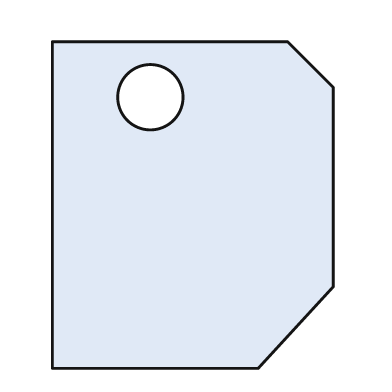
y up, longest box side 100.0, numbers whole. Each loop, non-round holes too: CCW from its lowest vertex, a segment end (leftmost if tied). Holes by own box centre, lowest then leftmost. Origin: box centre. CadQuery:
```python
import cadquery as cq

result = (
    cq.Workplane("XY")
    .moveTo(-43.0, -50.0)
    .lineTo(20.0, -50.0)
    .lineTo(43.0, -25.0)
    .lineTo(43.0, 36.0)
    .lineTo(29.0, 50.0)
    .lineTo(-43.0, 50.0)
    .close()
    .moveTo(-13.0, 33.0)
    .circle(10.0)
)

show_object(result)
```